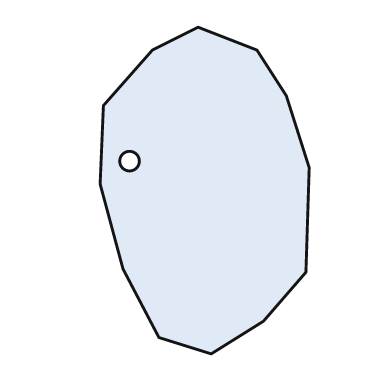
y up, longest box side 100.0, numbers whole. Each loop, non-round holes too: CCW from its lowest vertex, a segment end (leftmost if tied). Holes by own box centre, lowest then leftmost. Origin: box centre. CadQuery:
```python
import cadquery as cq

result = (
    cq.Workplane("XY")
    .moveTo(2.0, -50.0)
    .lineTo(18.0, -40.0)
    .lineTo(31.0, -25.0)
    .lineTo(32.0, 7.0)
    .lineTo(25.0, 29.0)
    .lineTo(16.0, 43.0)
    .lineTo(-2.0, 50.0)
    .lineTo(-16.0, 43.0)
    .lineTo(-31.0, 26.0)
    .lineTo(-32.0, 2.0)
    .lineTo(-25.0, -24.0)
    .lineTo(-14.0, -45.0)
    .close()
    .moveTo(-23.0, 9.0)
    .circle(3.0)
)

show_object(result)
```